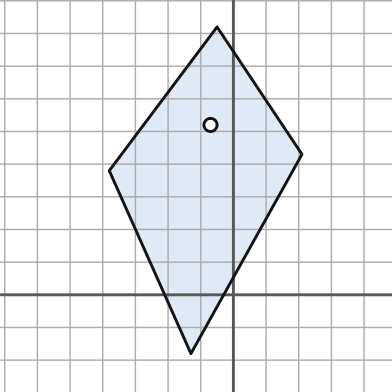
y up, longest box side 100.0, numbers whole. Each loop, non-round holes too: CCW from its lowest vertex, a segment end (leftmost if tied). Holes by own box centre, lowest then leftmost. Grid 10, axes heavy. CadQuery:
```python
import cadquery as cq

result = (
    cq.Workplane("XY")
    .moveTo(-13.0, -18.0)
    .lineTo(21.0, 43.0)
    .lineTo(-5.0, 82.0)
    .lineTo(-38.0, 38.0)
    .close()
    .moveTo(-7.0, 52.0)
    .circle(2.0)
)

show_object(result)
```